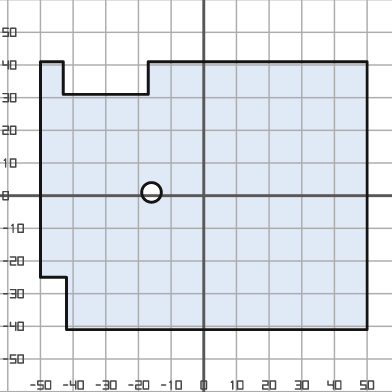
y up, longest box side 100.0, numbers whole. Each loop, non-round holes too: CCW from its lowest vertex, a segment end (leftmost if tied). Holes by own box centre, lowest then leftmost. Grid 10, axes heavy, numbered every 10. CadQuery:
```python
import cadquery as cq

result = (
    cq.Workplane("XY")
    .moveTo(-42.0, -41.0)
    .lineTo(50.0, -41.0)
    .lineTo(50.0, 41.0)
    .lineTo(-17.0, 41.0)
    .lineTo(-17.0, 31.0)
    .lineTo(-43.0, 31.0)
    .lineTo(-43.0, 41.0)
    .lineTo(-50.0, 41.0)
    .lineTo(-50.0, -25.0)
    .lineTo(-42.0, -25.0)
    .close()
    .moveTo(-16.0, 1.0)
    .circle(3.0)
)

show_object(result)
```